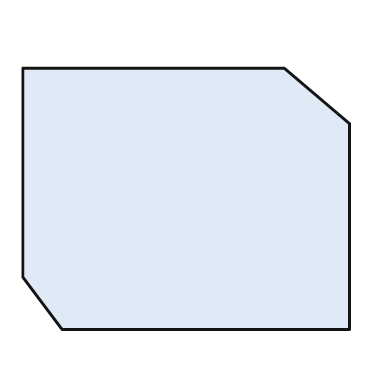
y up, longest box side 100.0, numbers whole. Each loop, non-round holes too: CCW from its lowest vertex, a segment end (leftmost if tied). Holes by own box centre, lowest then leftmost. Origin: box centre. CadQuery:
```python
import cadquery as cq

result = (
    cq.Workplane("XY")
    .moveTo(-38.0, -40.0)
    .lineTo(50.0, -40.0)
    .lineTo(50.0, 23.0)
    .lineTo(30.0, 40.0)
    .lineTo(-50.0, 40.0)
    .lineTo(-50.0, -24.0)
    .close()
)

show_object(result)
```